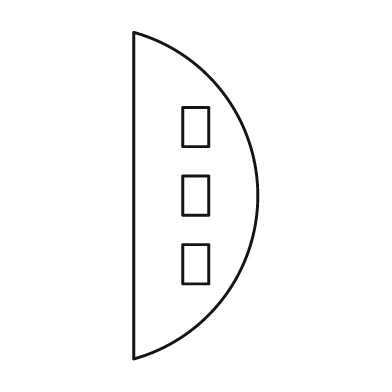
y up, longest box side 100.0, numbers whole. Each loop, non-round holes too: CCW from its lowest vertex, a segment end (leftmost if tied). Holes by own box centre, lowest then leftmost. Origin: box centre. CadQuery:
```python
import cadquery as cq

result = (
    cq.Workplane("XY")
    .moveTo(-19.0, -50.0)
    .threePointArc((19.0, 0.0), (-19.0, 50.0))
    .close()
    .moveTo(-4.0, -27.0)
    .lineTo(4.0, -27.0)
    .lineTo(4.0, -15.0)
    .lineTo(-4.0, -15.0)
    .close()
    .moveTo(-4.0, -6.0)
    .lineTo(4.0, -6.0)
    .lineTo(4.0, 6.0)
    .lineTo(-4.0, 6.0)
    .close()
    .moveTo(-4.0, 15.0)
    .lineTo(4.0, 15.0)
    .lineTo(4.0, 27.0)
    .lineTo(-4.0, 27.0)
    .close()
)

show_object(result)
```